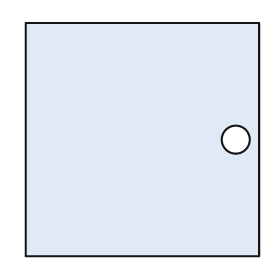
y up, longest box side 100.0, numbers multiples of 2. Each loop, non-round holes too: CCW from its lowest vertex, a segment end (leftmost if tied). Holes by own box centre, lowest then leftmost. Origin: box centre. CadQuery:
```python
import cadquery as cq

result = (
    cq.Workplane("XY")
    .moveTo(-50.0, -50.0)
    .lineTo(50.0, -50.0)
    .lineTo(50.0, 50.0)
    .lineTo(-50.0, 50.0)
    .close()
    .moveTo(40.0, 0.0)
    .circle(6.0)
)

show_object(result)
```